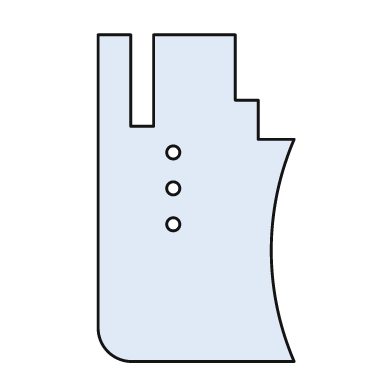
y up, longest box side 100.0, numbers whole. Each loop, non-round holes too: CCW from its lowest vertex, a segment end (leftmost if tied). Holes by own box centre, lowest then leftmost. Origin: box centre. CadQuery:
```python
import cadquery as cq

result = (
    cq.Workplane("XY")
    .moveTo(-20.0, -50.0)
    .lineTo(30.0, -50.0)
    .threePointArc((23.0, -16.0), (30.0, 18.0))
    .lineTo(19.0, 18.0)
    .lineTo(19.0, 30.0)
    .lineTo(12.0, 30.0)
    .lineTo(12.0, 50.0)
    .lineTo(-13.0, 50.0)
    .lineTo(-13.0, 22.0)
    .lineTo(-20.0, 22.0)
    .lineTo(-20.0, 50.0)
    .lineTo(-30.0, 50.0)
    .lineTo(-30.0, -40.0)
    .threePointArc((-27.0, -47.0), (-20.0, -50.0))
    .close()
    .moveTo(-7.0, -8.0)
    .circle(2.0)
    .moveTo(-7.0, 3.0)
    .circle(2.0)
    .moveTo(-7.0, 14.0)
    .circle(2.0)
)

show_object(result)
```